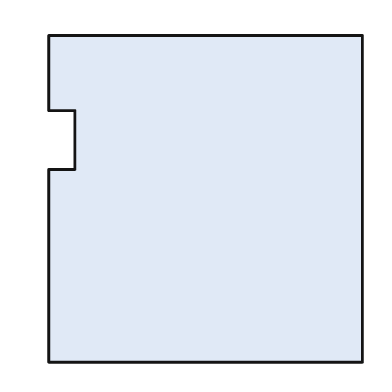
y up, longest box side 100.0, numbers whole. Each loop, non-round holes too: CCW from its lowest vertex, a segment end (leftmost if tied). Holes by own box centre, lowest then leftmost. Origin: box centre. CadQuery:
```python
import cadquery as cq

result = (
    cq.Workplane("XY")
    .moveTo(-48.0, -50.0)
    .lineTo(48.0, -50.0)
    .lineTo(48.0, 50.0)
    .lineTo(-48.0, 50.0)
    .lineTo(-48.0, 27.0)
    .lineTo(-40.0, 27.0)
    .lineTo(-40.0, 9.0)
    .lineTo(-48.0, 9.0)
    .close()
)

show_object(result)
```